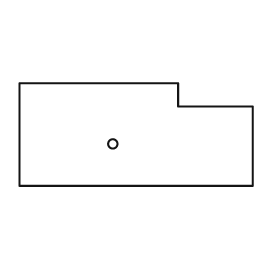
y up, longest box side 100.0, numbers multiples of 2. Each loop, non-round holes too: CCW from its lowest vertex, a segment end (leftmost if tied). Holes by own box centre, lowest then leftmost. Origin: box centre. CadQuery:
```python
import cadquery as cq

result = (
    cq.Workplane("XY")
    .moveTo(-50.0, -22.0)
    .lineTo(50.0, -22.0)
    .lineTo(50.0, 12.0)
    .lineTo(18.0, 12.0)
    .lineTo(18.0, 22.0)
    .lineTo(-50.0, 22.0)
    .close()
    .moveTo(-10.0, -4.0)
    .circle(2.0)
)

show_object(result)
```